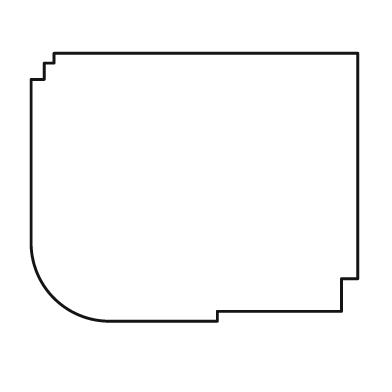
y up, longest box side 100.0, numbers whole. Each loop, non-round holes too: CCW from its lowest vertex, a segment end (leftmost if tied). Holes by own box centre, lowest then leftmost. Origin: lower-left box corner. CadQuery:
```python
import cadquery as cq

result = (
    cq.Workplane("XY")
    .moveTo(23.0, 0.0)
    .lineTo(57.0, 0.0)
    .lineTo(57.0, 3.0)
    .lineTo(95.0, 3.0)
    .lineTo(95.0, 13.0)
    .lineTo(100.0, 13.0)
    .lineTo(100.0, 82.0)
    .lineTo(7.0, 82.0)
    .lineTo(7.0, 79.0)
    .lineTo(4.0, 79.0)
    .lineTo(4.0, 74.0)
    .lineTo(0.0, 74.0)
    .lineTo(0.0, 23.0)
    .threePointArc((7.0, 7.0), (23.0, 0.0))
    .close()
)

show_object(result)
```